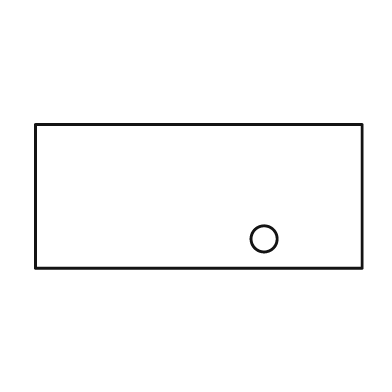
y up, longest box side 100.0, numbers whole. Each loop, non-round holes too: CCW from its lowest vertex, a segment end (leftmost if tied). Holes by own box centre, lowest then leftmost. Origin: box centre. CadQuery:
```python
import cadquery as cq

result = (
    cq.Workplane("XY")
    .moveTo(-50.0, -22.0)
    .lineTo(50.0, -22.0)
    .lineTo(50.0, 22.0)
    .lineTo(-50.0, 22.0)
    .close()
    .moveTo(20.0, -13.0)
    .circle(4.0)
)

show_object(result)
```